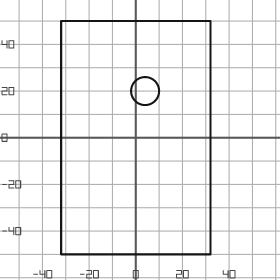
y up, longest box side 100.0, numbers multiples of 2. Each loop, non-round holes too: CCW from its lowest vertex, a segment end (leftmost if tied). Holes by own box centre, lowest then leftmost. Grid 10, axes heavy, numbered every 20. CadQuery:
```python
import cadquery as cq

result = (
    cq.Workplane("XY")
    .moveTo(-32.0, -50.0)
    .lineTo(32.0, -50.0)
    .lineTo(32.0, 50.0)
    .lineTo(-32.0, 50.0)
    .close()
    .moveTo(4.0, 20.0)
    .circle(6.0)
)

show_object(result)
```